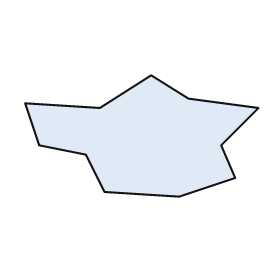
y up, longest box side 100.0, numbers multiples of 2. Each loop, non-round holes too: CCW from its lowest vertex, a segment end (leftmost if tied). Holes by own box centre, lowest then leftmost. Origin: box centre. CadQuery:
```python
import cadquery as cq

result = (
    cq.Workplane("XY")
    .moveTo(16.0, -26.0)
    .lineTo(40.0, -18.0)
    .lineTo(34.0, -4.0)
    .lineTo(50.0, 12.0)
    .lineTo(20.0, 16.0)
    .lineTo(4.0, 26.0)
    .lineTo(-18.0, 12.0)
    .lineTo(-50.0, 14.0)
    .lineTo(-44.0, -4.0)
    .lineTo(-24.0, -8.0)
    .lineTo(-16.0, -24.0)
    .close()
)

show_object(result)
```